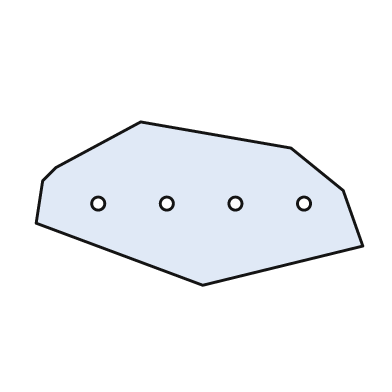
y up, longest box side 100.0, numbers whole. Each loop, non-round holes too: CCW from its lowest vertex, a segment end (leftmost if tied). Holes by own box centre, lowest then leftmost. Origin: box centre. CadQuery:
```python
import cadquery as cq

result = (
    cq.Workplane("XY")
    .moveTo(1.0, -25.0)
    .lineTo(50.0, -13.0)
    .lineTo(44.0, 4.0)
    .lineTo(28.0, 17.0)
    .lineTo(-18.0, 25.0)
    .lineTo(-44.0, 11.0)
    .lineTo(-48.0, 7.0)
    .lineTo(-50.0, -6.0)
    .close()
    .moveTo(-31.0, 0.0)
    .circle(2.0)
    .moveTo(-10.0, 0.0)
    .circle(2.0)
    .moveTo(11.0, 0.0)
    .circle(2.0)
    .moveTo(32.0, 0.0)
    .circle(2.0)
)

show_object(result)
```